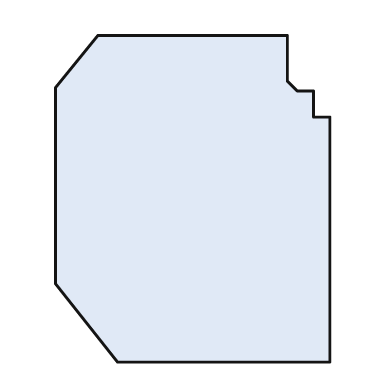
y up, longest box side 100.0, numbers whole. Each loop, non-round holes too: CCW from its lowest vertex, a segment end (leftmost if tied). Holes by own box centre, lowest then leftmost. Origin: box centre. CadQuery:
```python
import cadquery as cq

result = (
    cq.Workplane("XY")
    .moveTo(-23.0, -50.0)
    .lineTo(42.0, -50.0)
    .lineTo(42.0, 25.0)
    .lineTo(37.0, 25.0)
    .lineTo(37.0, 33.0)
    .lineTo(32.0, 33.0)
    .lineTo(29.0, 36.0)
    .lineTo(29.0, 50.0)
    .lineTo(-29.0, 50.0)
    .lineTo(-42.0, 34.0)
    .lineTo(-42.0, -26.0)
    .close()
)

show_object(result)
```